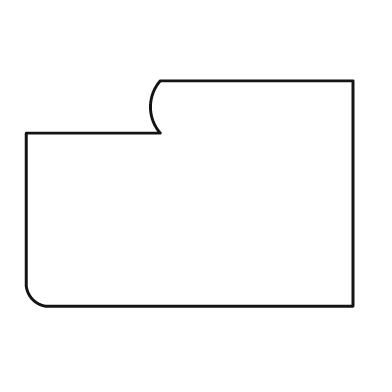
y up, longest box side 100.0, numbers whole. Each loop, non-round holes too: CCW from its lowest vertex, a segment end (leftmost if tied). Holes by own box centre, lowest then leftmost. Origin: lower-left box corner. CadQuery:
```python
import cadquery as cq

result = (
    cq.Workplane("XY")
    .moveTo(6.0, 0.0)
    .lineTo(100.0, 0.0)
    .lineTo(100.0, 69.0)
    .lineTo(41.0, 69.0)
    .threePointArc((38.0, 61.0), (41.0, 53.0))
    .lineTo(0.0, 53.0)
    .lineTo(0.0, 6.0)
    .threePointArc((2.0, 2.0), (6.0, 0.0))
    .close()
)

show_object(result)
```